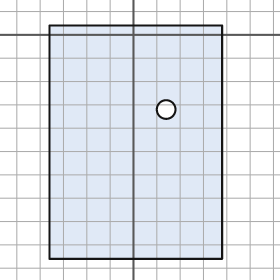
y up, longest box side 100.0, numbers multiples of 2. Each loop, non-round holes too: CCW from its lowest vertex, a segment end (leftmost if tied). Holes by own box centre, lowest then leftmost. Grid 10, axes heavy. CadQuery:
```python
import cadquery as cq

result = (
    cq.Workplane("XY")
    .moveTo(-36.0, -96.0)
    .lineTo(38.0, -96.0)
    .lineTo(38.0, 4.0)
    .lineTo(-36.0, 4.0)
    .close()
    .moveTo(14.0, -32.0)
    .circle(4.0)
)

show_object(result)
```